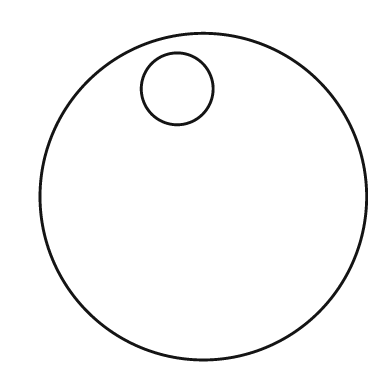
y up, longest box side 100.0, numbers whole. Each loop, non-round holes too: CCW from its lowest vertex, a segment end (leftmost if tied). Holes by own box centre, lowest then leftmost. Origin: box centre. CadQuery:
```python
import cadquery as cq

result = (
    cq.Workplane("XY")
    .moveTo(0.0, 0.0)
    .circle(50.0)
    .moveTo(-8.0, 33.0)
    .circle(11.0)
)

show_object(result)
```